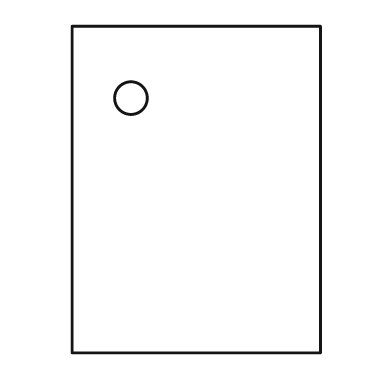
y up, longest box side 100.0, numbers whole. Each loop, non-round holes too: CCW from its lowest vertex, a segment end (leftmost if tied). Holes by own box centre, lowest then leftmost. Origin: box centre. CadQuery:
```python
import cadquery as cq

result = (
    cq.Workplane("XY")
    .moveTo(-38.0, -50.0)
    .lineTo(38.0, -50.0)
    .lineTo(38.0, 50.0)
    .lineTo(-38.0, 50.0)
    .close()
    .moveTo(-20.0, 28.0)
    .circle(5.0)
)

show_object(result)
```